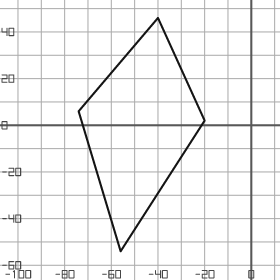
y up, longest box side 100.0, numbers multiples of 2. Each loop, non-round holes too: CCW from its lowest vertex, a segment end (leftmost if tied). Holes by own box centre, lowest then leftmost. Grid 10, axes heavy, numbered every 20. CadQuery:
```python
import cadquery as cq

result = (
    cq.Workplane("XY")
    .moveTo(-56.0, -54.0)
    .lineTo(-20.0, 2.0)
    .lineTo(-40.0, 46.0)
    .lineTo(-74.0, 6.0)
    .close()
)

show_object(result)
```